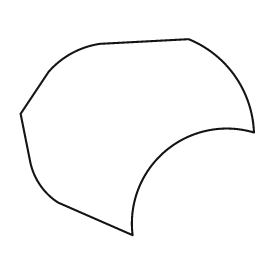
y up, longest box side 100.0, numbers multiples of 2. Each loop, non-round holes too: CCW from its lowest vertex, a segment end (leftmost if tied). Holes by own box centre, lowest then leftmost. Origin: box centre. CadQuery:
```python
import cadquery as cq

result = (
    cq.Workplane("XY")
    .moveTo(-2.0, -42.0)
    .threePointArc((12.0, -6.0), (50.0, 2.0))
    .threePointArc((42.0, 26.0), (22.0, 42.0))
    .lineTo(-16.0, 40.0)
    .threePointArc((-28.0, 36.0), (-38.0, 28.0))
    .lineTo(-50.0, 10.0)
    .lineTo(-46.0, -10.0)
    .threePointArc((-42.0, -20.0), (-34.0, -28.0))
    .close()
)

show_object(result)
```